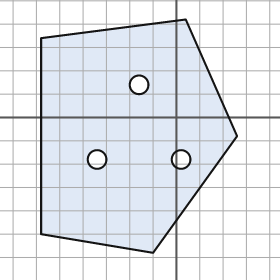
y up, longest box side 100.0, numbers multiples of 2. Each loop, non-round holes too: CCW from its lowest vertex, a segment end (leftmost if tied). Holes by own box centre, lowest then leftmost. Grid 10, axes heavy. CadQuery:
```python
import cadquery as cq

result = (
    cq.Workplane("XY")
    .moveTo(-10.0, -58.0)
    .lineTo(26.0, -8.0)
    .lineTo(4.0, 42.0)
    .lineTo(-58.0, 34.0)
    .lineTo(-58.0, -50.0)
    .close()
    .moveTo(-34.0, -18.0)
    .circle(4.0)
    .moveTo(2.0, -18.0)
    .circle(4.0)
    .moveTo(-16.0, 14.0)
    .circle(4.0)
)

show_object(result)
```